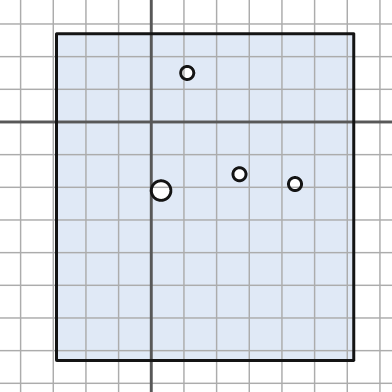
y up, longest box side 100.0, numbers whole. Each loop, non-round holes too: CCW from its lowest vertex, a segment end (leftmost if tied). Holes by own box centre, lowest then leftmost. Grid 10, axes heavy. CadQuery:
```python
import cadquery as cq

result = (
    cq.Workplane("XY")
    .moveTo(-29.0, -73.0)
    .lineTo(62.0, -73.0)
    .lineTo(62.0, 27.0)
    .lineTo(-29.0, 27.0)
    .close()
    .moveTo(3.0, -21.0)
    .circle(3.0)
    .moveTo(44.0, -19.0)
    .circle(2.0)
    .moveTo(27.0, -16.0)
    .circle(2.0)
    .moveTo(11.0, 15.0)
    .circle(2.0)
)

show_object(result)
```